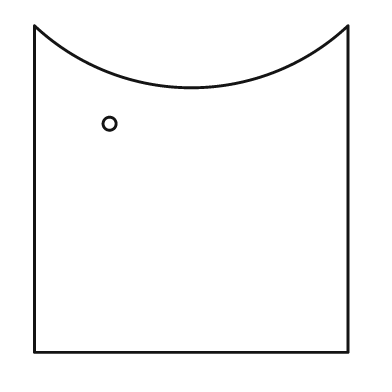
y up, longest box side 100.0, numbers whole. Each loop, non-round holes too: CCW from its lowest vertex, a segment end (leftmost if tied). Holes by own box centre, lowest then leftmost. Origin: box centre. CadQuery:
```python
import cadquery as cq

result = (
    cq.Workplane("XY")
    .moveTo(-48.0, -50.0)
    .lineTo(48.0, -50.0)
    .lineTo(48.0, 50.0)
    .threePointArc((0.0, 31.0), (-48.0, 50.0))
    .close()
    .moveTo(-25.0, 20.0)
    .circle(2.0)
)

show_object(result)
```